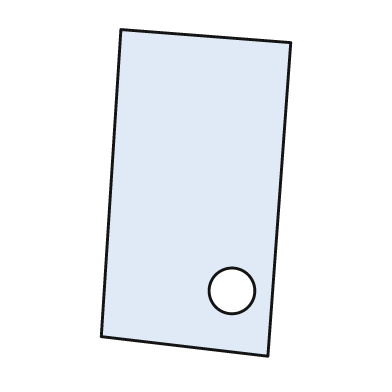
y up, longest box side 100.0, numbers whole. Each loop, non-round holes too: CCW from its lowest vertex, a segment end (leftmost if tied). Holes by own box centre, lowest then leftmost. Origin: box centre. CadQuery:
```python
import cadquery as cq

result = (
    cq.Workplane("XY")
    .moveTo(22.0, -50.0)
    .lineTo(29.0, 46.0)
    .lineTo(-23.0, 50.0)
    .lineTo(-29.0, -44.0)
    .close()
    .moveTo(11.0, -30.0)
    .circle(7.0)
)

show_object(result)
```